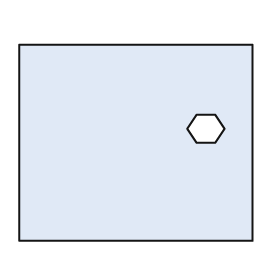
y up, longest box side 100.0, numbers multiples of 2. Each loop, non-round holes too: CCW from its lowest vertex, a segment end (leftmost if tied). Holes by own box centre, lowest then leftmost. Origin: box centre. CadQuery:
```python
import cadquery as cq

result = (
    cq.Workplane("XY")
    .moveTo(-50.0, -42.0)
    .lineTo(50.0, -42.0)
    .lineTo(50.0, 42.0)
    .lineTo(-50.0, 42.0)
    .close()
    .moveTo(26.0, 0.0)
    .lineTo(34.0, 0.0)
    .lineTo(38.0, 6.0)
    .lineTo(34.0, 12.0)
    .lineTo(26.0, 12.0)
    .lineTo(22.0, 6.0)
    .close()
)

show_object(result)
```